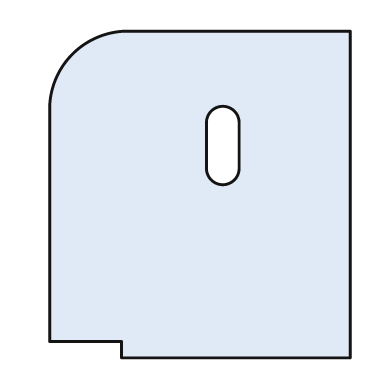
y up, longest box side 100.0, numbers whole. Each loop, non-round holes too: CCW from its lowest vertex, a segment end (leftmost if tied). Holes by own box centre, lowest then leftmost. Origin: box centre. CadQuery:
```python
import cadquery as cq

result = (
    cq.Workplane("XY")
    .moveTo(-24.0, -50.0)
    .lineTo(46.0, -50.0)
    .lineTo(46.0, 50.0)
    .lineTo(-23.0, 50.0)
    .threePointArc((-39.0, 43.0), (-46.0, 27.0))
    .lineTo(-46.0, -45.0)
    .lineTo(-24.0, -45.0)
    .close()
    .moveTo(2.0, 8.0)
    .threePointArc((7.0, 3.0), (12.0, 8.0))
    .lineTo(12.0, 22.0)
    .threePointArc((7.0, 27.0), (2.0, 22.0))
    .close()
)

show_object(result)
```